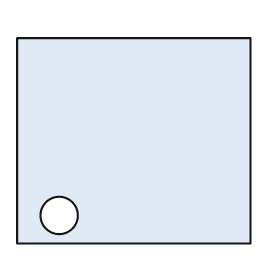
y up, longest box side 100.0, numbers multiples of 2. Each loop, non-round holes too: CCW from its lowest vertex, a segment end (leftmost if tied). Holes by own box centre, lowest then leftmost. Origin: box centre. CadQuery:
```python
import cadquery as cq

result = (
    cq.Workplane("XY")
    .moveTo(-50.0, -44.0)
    .lineTo(50.0, -44.0)
    .lineTo(50.0, 44.0)
    .lineTo(-50.0, 44.0)
    .close()
    .moveTo(-32.0, -32.0)
    .circle(8.0)
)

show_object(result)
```